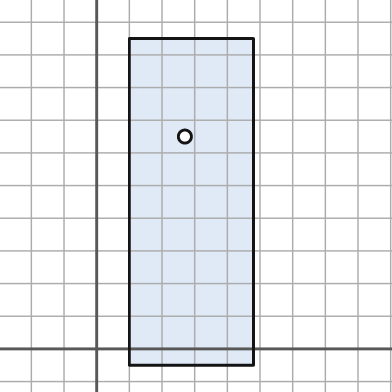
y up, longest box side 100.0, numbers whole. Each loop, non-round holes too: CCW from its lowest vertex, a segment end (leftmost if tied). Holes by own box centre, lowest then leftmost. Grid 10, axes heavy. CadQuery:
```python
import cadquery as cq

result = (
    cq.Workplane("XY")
    .moveTo(10.0, -5.0)
    .lineTo(48.0, -5.0)
    .lineTo(48.0, 95.0)
    .lineTo(10.0, 95.0)
    .close()
    .moveTo(27.0, 65.0)
    .circle(2.0)
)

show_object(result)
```